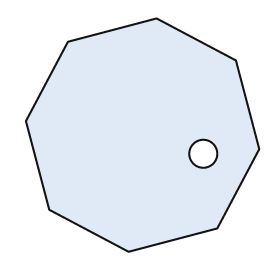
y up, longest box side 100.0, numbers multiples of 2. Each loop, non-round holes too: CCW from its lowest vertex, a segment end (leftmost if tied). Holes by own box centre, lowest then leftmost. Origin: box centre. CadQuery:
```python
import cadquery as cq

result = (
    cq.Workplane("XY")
    .moveTo(-6.0, -50.0)
    .lineTo(32.0, -40.0)
    .lineTo(50.0, -6.0)
    .lineTo(40.0, 32.0)
    .lineTo(6.0, 50.0)
    .lineTo(-32.0, 40.0)
    .lineTo(-50.0, 6.0)
    .lineTo(-40.0, -32.0)
    .close()
    .moveTo(26.0, -8.0)
    .circle(6.0)
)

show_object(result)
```